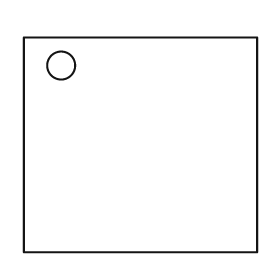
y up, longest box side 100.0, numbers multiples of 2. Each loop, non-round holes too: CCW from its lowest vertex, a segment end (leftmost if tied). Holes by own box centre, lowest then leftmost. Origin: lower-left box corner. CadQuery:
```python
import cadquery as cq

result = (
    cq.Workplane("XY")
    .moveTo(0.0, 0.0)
    .lineTo(100.0, 0.0)
    .lineTo(100.0, 92.0)
    .lineTo(0.0, 92.0)
    .close()
    .moveTo(16.0, 80.0)
    .circle(6.0)
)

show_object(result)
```